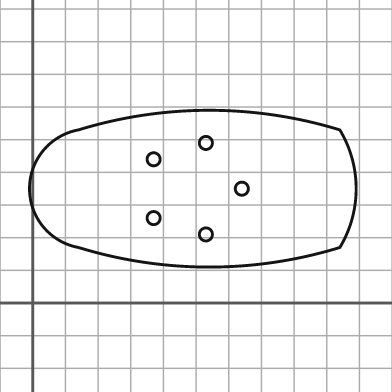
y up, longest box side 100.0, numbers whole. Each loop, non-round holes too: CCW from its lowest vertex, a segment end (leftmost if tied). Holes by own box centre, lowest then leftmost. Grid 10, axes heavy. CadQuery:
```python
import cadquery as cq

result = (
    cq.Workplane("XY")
    .moveTo(14.0, 17.0)
    .threePointArc((54.0, 11.0), (94.0, 17.0))
    .threePointArc((99.0, 35.0), (94.0, 53.0))
    .threePointArc((54.0, 59.0), (14.0, 53.0))
    .threePointArc((-1.0, 35.0), (14.0, 17.0))
    .close()
    .moveTo(53.0, 21.0)
    .circle(2.0)
    .moveTo(37.0, 26.0)
    .circle(2.0)
    .moveTo(64.0, 35.0)
    .circle(2.0)
    .moveTo(37.0, 44.0)
    .circle(2.0)
    .moveTo(53.0, 49.0)
    .circle(2.0)
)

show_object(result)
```